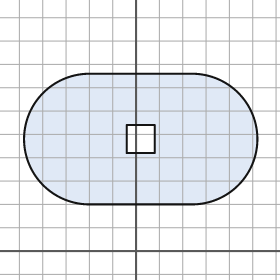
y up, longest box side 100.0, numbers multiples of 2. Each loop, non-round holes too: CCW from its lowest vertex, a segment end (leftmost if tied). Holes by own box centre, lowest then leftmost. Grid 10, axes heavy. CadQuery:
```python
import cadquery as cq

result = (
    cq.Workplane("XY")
    .moveTo(-20.0, 20.0)
    .lineTo(24.0, 20.0)
    .threePointArc((52.0, 48.0), (24.0, 76.0))
    .lineTo(-20.0, 76.0)
    .threePointArc((-48.0, 48.0), (-20.0, 20.0))
    .close()
    .moveTo(-4.0, 42.0)
    .lineTo(8.0, 42.0)
    .lineTo(8.0, 54.0)
    .lineTo(-4.0, 54.0)
    .close()
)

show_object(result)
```